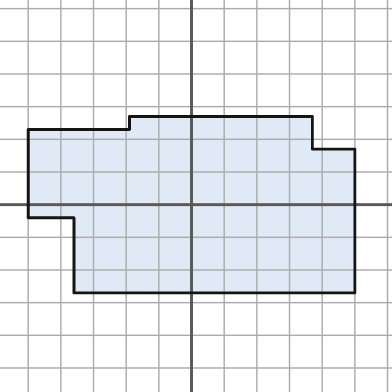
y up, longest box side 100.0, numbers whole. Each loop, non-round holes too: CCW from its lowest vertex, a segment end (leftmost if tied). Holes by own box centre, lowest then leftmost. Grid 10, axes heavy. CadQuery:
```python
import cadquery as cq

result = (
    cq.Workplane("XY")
    .moveTo(-36.0, -27.0)
    .lineTo(50.0, -27.0)
    .lineTo(50.0, 17.0)
    .lineTo(37.0, 17.0)
    .lineTo(37.0, 27.0)
    .lineTo(-19.0, 27.0)
    .lineTo(-19.0, 23.0)
    .lineTo(-50.0, 23.0)
    .lineTo(-50.0, -4.0)
    .lineTo(-36.0, -4.0)
    .close()
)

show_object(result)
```